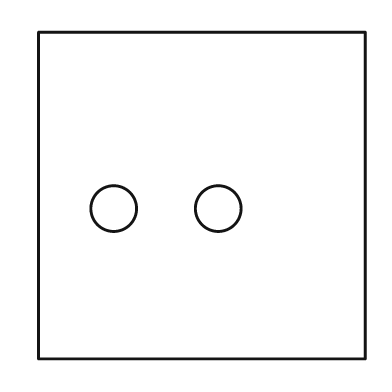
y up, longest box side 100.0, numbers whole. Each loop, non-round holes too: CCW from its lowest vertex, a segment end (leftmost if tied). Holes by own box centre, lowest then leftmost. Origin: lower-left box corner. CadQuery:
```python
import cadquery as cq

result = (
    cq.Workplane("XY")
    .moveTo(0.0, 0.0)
    .lineTo(100.0, 0.0)
    .lineTo(100.0, 100.0)
    .lineTo(0.0, 100.0)
    .close()
    .moveTo(23.0, 46.0)
    .circle(7.0)
    .moveTo(55.0, 46.0)
    .circle(7.0)
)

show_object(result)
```